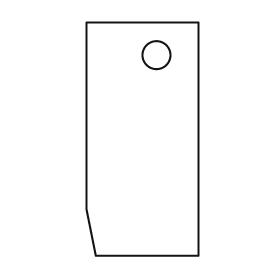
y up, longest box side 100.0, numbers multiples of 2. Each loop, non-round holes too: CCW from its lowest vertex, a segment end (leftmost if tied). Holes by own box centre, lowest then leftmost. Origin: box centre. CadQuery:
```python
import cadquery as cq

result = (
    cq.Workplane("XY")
    .moveTo(-20.0, -50.0)
    .lineTo(24.0, -50.0)
    .lineTo(24.0, 50.0)
    .lineTo(-24.0, 50.0)
    .lineTo(-24.0, -30.0)
    .close()
    .moveTo(6.0, 36.0)
    .circle(6.0)
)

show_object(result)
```